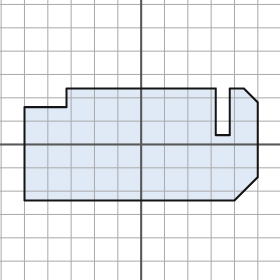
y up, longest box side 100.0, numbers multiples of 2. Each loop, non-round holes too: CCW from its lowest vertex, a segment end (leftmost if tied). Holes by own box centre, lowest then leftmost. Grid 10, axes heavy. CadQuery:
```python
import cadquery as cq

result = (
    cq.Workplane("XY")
    .moveTo(-50.0, -24.0)
    .lineTo(40.0, -24.0)
    .lineTo(50.0, -14.0)
    .lineTo(50.0, 18.0)
    .lineTo(44.0, 24.0)
    .lineTo(38.0, 24.0)
    .lineTo(38.0, 4.0)
    .lineTo(32.0, 4.0)
    .lineTo(32.0, 24.0)
    .lineTo(-32.0, 24.0)
    .lineTo(-32.0, 16.0)
    .lineTo(-50.0, 16.0)
    .close()
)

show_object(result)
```